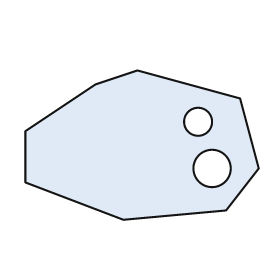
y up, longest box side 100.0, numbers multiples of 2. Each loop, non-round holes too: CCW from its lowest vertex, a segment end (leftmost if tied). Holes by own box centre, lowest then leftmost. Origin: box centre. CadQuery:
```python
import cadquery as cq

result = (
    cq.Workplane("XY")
    .moveTo(-8.0, -32.0)
    .lineTo(36.0, -28.0)
    .lineTo(50.0, -10.0)
    .lineTo(42.0, 20.0)
    .lineTo(-2.0, 32.0)
    .lineTo(-20.0, 26.0)
    .lineTo(-50.0, 6.0)
    .lineTo(-50.0, -16.0)
    .close()
    .moveTo(30.0, -10.0)
    .circle(8.0)
    .moveTo(24.0, 10.0)
    .circle(6.0)
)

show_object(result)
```